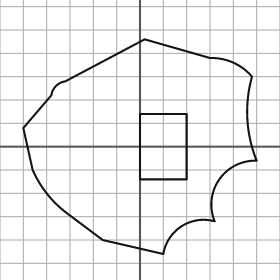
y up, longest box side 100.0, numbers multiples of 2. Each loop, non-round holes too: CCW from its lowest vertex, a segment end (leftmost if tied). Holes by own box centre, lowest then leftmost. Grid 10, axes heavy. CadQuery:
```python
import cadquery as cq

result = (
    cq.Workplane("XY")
    .moveTo(10.0, -46.0)
    .threePointArc((18.0, -34.0), (32.0, -32.0))
    .threePointArc((34.0, -14.0), (50.0, -6.0))
    .threePointArc((46.0, 12.0), (48.0, 30.0))
    .threePointArc((40.0, 36.0), (30.0, 38.0))
    .lineTo(2.0, 46.0)
    .lineTo(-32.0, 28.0)
    .threePointArc((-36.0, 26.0), (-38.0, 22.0))
    .lineTo(-50.0, 8.0)
    .lineTo(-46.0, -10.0)
    .threePointArc((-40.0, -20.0), (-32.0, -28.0))
    .lineTo(-16.0, -40.0)
    .close()
    .moveTo(0.0, -14.0)
    .lineTo(20.0, -14.0)
    .lineTo(20.0, 14.0)
    .lineTo(0.0, 14.0)
    .close()
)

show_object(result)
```